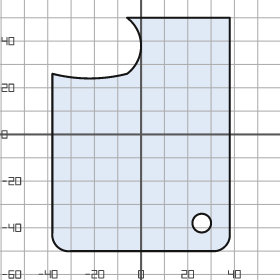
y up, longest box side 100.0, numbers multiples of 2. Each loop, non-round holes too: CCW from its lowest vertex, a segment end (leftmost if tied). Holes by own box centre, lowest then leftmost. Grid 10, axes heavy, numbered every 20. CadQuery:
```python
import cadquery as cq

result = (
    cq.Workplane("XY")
    .moveTo(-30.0, -50.0)
    .lineTo(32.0, -50.0)
    .threePointArc((36.0, -48.0), (38.0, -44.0))
    .lineTo(38.0, 50.0)
    .lineTo(-6.0, 50.0)
    .threePointArc((0.0, 38.0), (-6.0, 26.0))
    .threePointArc((-22.0, 24.0), (-38.0, 26.0))
    .lineTo(-38.0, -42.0)
    .threePointArc((-36.0, -48.0), (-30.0, -50.0))
    .close()
    .moveTo(26.0, -38.0)
    .circle(4.0)
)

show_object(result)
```